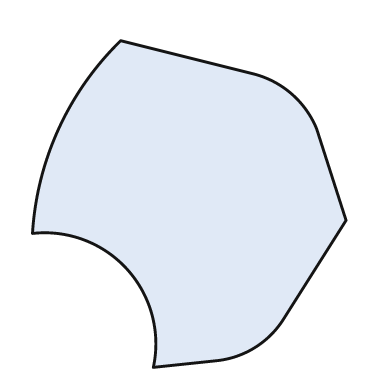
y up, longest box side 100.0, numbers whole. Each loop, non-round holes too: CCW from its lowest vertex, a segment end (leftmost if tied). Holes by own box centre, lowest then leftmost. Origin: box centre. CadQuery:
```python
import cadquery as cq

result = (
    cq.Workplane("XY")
    .moveTo(-11.0, -50.0)
    .lineTo(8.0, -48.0)
    .threePointArc((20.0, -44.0), (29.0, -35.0))
    .lineTo(48.0, -5.0)
    .lineTo(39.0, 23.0)
    .threePointArc((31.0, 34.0), (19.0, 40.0))
    .lineTo(-21.0, 50.0)
    .threePointArc((-40.0, 23.0), (-48.0, -9.0))
    .threePointArc((-19.0, -20.0), (-11.0, -50.0))
    .close()
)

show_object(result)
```